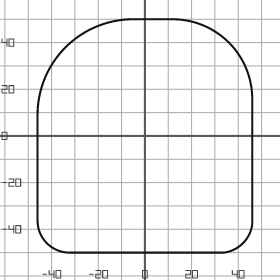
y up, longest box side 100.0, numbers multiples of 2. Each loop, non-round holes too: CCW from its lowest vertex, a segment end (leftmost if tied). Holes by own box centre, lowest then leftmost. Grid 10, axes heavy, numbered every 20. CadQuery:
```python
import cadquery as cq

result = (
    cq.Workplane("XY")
    .moveTo(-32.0, -50.0)
    .lineTo(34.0, -50.0)
    .threePointArc((42.0, -46.0), (46.0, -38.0))
    .lineTo(46.0, 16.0)
    .threePointArc((36.0, 40.0), (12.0, 50.0))
    .lineTo(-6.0, 50.0)
    .threePointArc((-34.0, 38.0), (-46.0, 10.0))
    .lineTo(-46.0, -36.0)
    .threePointArc((-42.0, -46.0), (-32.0, -50.0))
    .close()
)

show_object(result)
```